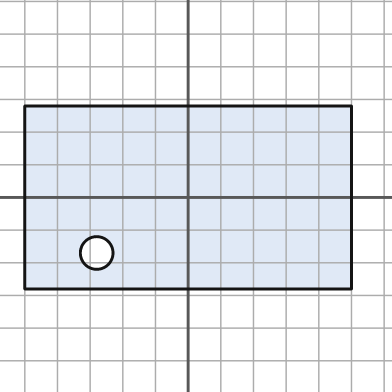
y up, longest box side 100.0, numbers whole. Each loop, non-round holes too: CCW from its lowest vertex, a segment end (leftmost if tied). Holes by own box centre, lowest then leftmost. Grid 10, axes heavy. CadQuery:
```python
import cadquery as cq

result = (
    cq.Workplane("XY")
    .moveTo(-50.0, -28.0)
    .lineTo(50.0, -28.0)
    .lineTo(50.0, 28.0)
    .lineTo(-50.0, 28.0)
    .close()
    .moveTo(-28.0, -17.0)
    .circle(5.0)
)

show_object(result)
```